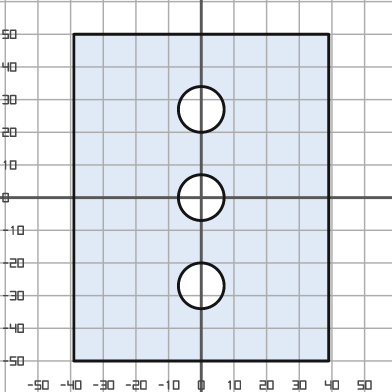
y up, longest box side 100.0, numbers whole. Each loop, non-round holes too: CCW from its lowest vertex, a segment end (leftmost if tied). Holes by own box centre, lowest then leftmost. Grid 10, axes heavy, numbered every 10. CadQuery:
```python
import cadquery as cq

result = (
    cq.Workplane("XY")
    .moveTo(-39.0, -50.0)
    .lineTo(39.0, -50.0)
    .lineTo(39.0, 50.0)
    .lineTo(-39.0, 50.0)
    .close()
    .moveTo(0.0, -27.0)
    .circle(7.0)
    .moveTo(0.0, 0.0)
    .circle(7.0)
    .moveTo(0.0, 27.0)
    .circle(7.0)
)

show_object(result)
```